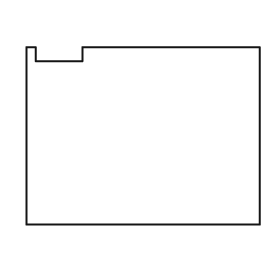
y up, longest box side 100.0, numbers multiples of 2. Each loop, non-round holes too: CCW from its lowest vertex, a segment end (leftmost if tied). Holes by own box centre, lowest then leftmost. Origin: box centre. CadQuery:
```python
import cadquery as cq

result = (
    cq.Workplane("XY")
    .moveTo(-50.0, -38.0)
    .lineTo(50.0, -38.0)
    .lineTo(50.0, 38.0)
    .lineTo(-26.0, 38.0)
    .lineTo(-26.0, 32.0)
    .lineTo(-46.0, 32.0)
    .lineTo(-46.0, 38.0)
    .lineTo(-50.0, 38.0)
    .close()
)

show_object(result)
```